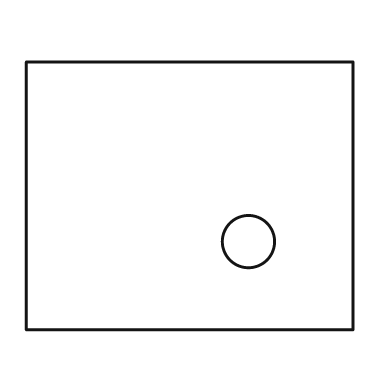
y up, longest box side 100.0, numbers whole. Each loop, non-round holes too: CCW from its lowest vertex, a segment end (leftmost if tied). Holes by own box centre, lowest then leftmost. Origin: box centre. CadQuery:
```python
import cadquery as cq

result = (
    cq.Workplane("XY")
    .moveTo(-50.0, -41.0)
    .lineTo(50.0, -41.0)
    .lineTo(50.0, 41.0)
    .lineTo(-50.0, 41.0)
    .close()
    .moveTo(18.0, -14.0)
    .circle(8.0)
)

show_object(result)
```